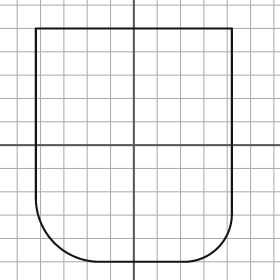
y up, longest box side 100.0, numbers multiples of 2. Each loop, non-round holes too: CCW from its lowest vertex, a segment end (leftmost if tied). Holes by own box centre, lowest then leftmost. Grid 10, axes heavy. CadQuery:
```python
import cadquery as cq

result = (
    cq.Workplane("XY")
    .moveTo(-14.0, -50.0)
    .lineTo(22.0, -50.0)
    .threePointArc((36.0, -44.0), (42.0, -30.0))
    .lineTo(42.0, 50.0)
    .lineTo(-42.0, 50.0)
    .lineTo(-42.0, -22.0)
    .threePointArc((-34.0, -42.0), (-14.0, -50.0))
    .close()
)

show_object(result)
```